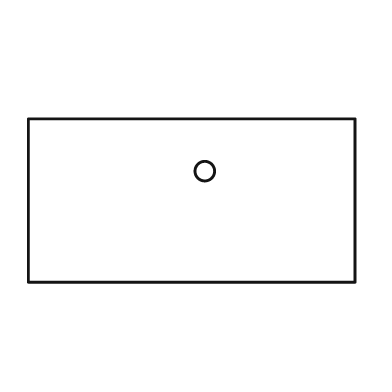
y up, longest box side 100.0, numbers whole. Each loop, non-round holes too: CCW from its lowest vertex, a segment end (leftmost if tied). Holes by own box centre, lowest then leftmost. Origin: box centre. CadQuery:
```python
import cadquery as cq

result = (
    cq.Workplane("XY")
    .moveTo(-50.0, -25.0)
    .lineTo(50.0, -25.0)
    .lineTo(50.0, 25.0)
    .lineTo(-50.0, 25.0)
    .close()
    .moveTo(4.0, 9.0)
    .circle(3.0)
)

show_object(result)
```